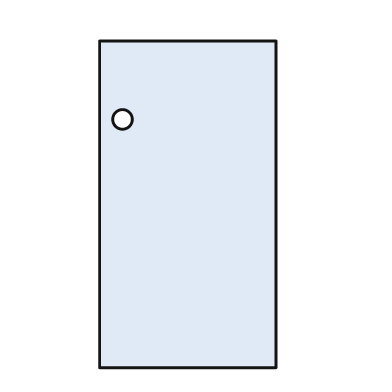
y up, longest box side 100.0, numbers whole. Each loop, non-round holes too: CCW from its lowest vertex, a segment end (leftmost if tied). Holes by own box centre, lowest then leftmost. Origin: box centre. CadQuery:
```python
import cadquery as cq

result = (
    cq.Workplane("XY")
    .moveTo(-27.0, -50.0)
    .lineTo(27.0, -50.0)
    .lineTo(27.0, 50.0)
    .lineTo(-27.0, 50.0)
    .close()
    .moveTo(-20.0, 26.0)
    .circle(3.0)
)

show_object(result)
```